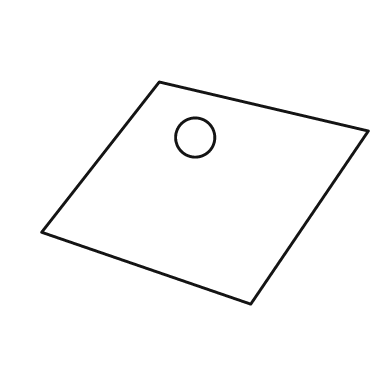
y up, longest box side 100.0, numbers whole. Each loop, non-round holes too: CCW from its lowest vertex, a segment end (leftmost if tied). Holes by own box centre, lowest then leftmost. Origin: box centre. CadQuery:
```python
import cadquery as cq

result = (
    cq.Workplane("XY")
    .moveTo(14.0, -34.0)
    .lineTo(50.0, 19.0)
    .lineTo(-14.0, 34.0)
    .lineTo(-50.0, -12.0)
    .close()
    .moveTo(-3.0, 17.0)
    .circle(6.0)
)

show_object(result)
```